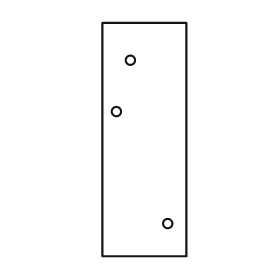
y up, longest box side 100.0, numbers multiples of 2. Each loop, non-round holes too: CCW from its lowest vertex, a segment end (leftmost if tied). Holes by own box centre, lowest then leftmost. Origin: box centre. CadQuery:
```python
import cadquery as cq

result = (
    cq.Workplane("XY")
    .moveTo(-18.0, -50.0)
    .lineTo(18.0, -50.0)
    .lineTo(18.0, 50.0)
    .lineTo(-18.0, 50.0)
    .close()
    .moveTo(10.0, -36.0)
    .circle(2.0)
    .moveTo(-12.0, 12.0)
    .circle(2.0)
    .moveTo(-6.0, 34.0)
    .circle(2.0)
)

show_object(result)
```